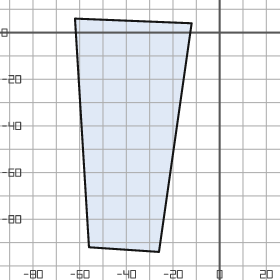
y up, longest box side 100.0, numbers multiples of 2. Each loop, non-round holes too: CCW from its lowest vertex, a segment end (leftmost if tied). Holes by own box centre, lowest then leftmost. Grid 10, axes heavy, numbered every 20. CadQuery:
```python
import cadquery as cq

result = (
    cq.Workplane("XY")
    .moveTo(-26.0, -94.0)
    .lineTo(-12.0, 4.0)
    .lineTo(-62.0, 6.0)
    .lineTo(-56.0, -92.0)
    .close()
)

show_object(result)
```